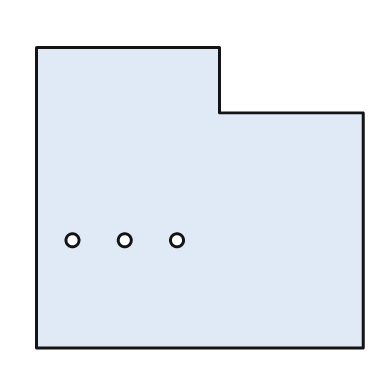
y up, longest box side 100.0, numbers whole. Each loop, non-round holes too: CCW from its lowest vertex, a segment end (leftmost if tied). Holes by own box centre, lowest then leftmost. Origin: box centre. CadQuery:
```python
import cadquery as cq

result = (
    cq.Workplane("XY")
    .moveTo(-50.0, -46.0)
    .lineTo(50.0, -46.0)
    .lineTo(50.0, 26.0)
    .lineTo(6.0, 26.0)
    .lineTo(6.0, 46.0)
    .lineTo(-50.0, 46.0)
    .close()
    .moveTo(-39.0, -13.0)
    .circle(2.0)
    .moveTo(-23.0, -13.0)
    .circle(2.0)
    .moveTo(-7.0, -13.0)
    .circle(2.0)
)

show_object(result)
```